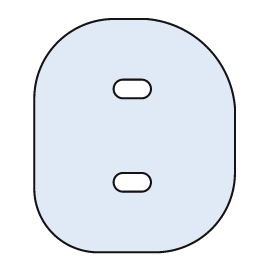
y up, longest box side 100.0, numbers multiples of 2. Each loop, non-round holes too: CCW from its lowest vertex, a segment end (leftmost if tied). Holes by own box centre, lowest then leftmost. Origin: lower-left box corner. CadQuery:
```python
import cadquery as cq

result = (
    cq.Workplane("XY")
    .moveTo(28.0, 0.0)
    .lineTo(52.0, 0.0)
    .threePointArc((76.0, 10.0), (86.0, 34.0))
    .lineTo(86.0, 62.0)
    .threePointArc((74.0, 88.0), (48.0, 100.0))
    .lineTo(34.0, 100.0)
    .threePointArc((10.0, 90.0), (0.0, 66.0))
    .lineTo(0.0, 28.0)
    .threePointArc((8.0, 8.0), (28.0, 0.0))
    .close()
    .moveTo(38.0, 26.0)
    .lineTo(46.0, 26.0)
    .threePointArc((50.0, 30.0), (46.0, 34.0))
    .lineTo(38.0, 34.0)
    .threePointArc((34.0, 30.0), (38.0, 26.0))
    .close()
    .moveTo(38.0, 66.0)
    .lineTo(46.0, 66.0)
    .threePointArc((50.0, 70.0), (46.0, 74.0))
    .lineTo(38.0, 74.0)
    .threePointArc((34.0, 70.0), (38.0, 66.0))
    .close()
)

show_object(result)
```